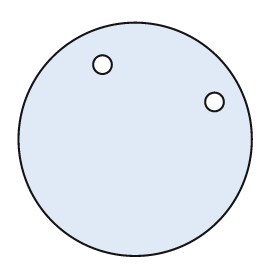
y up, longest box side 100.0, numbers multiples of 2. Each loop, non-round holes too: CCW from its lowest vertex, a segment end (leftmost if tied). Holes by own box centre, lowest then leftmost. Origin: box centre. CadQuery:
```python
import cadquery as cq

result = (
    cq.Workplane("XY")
    .moveTo(0.0, 0.0)
    .circle(50.0)
    .moveTo(34.0, 16.0)
    .circle(4.0)
    .moveTo(-14.0, 32.0)
    .circle(4.0)
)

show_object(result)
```